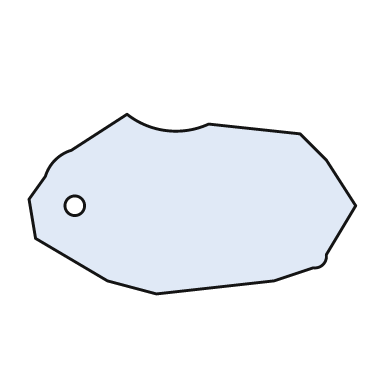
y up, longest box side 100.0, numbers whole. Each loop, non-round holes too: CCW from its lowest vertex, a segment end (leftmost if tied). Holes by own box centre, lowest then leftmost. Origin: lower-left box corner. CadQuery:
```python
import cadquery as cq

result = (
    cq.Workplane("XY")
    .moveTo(39.0, 0.0)
    .lineTo(75.0, 4.0)
    .lineTo(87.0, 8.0)
    .threePointArc((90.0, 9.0), (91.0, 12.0))
    .lineTo(100.0, 27.0)
    .lineTo(91.0, 41.0)
    .lineTo(83.0, 49.0)
    .lineTo(55.0, 52.0)
    .threePointArc((42.0, 50.0), (30.0, 55.0))
    .lineTo(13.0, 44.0)
    .threePointArc((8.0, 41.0), (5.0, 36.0))
    .lineTo(0.0, 29.0)
    .lineTo(2.0, 17.0)
    .lineTo(24.0, 4.0)
    .close()
    .moveTo(14.0, 27.0)
    .circle(3.0)
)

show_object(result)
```